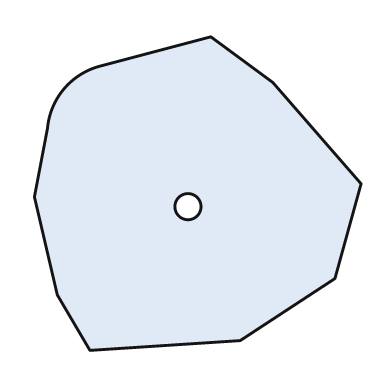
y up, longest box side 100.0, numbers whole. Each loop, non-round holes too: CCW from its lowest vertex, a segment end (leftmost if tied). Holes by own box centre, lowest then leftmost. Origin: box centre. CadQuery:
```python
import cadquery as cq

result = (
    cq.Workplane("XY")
    .moveTo(-33.0, -48.0)
    .lineTo(13.0, -45.0)
    .lineTo(42.0, -26.0)
    .lineTo(50.0, 3.0)
    .lineTo(23.0, 34.0)
    .lineTo(4.0, 48.0)
    .lineTo(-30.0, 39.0)
    .threePointArc((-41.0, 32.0), (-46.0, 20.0))
    .lineTo(-50.0, -1.0)
    .lineTo(-43.0, -31.0)
    .close()
    .moveTo(-3.0, -4.0)
    .circle(4.0)
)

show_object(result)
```